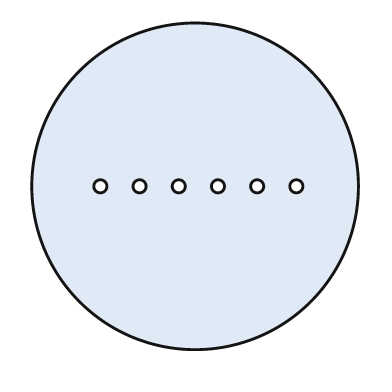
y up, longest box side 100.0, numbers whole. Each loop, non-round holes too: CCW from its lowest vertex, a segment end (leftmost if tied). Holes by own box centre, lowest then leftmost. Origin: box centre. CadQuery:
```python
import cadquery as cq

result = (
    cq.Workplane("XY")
    .moveTo(0.0, 0.0)
    .circle(50.0)
    .moveTo(-29.0, 0.0)
    .circle(2.0)
    .moveTo(-17.0, 0.0)
    .circle(2.0)
    .moveTo(-5.0, 0.0)
    .circle(2.0)
    .moveTo(7.0, 0.0)
    .circle(2.0)
    .moveTo(19.0, 0.0)
    .circle(2.0)
    .moveTo(31.0, 0.0)
    .circle(2.0)
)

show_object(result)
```